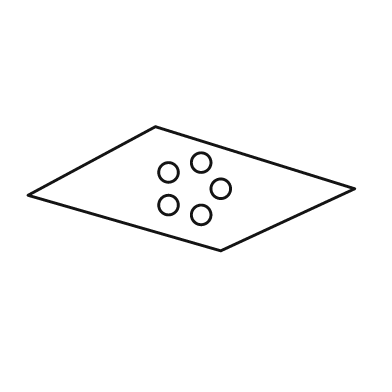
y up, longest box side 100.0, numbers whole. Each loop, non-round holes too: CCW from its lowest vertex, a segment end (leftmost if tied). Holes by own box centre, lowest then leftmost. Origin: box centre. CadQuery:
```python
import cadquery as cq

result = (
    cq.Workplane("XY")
    .moveTo(9.0, -19.0)
    .lineTo(50.0, 0.0)
    .lineTo(-11.0, 19.0)
    .lineTo(-50.0, -2.0)
    .close()
    .moveTo(3.0, -8.0)
    .circle(3.0)
    .moveTo(-7.0, -5.0)
    .circle(3.0)
    .moveTo(9.0, 0.0)
    .circle(3.0)
    .moveTo(-7.0, 5.0)
    .circle(3.0)
    .moveTo(3.0, 8.0)
    .circle(3.0)
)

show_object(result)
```